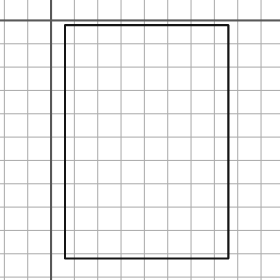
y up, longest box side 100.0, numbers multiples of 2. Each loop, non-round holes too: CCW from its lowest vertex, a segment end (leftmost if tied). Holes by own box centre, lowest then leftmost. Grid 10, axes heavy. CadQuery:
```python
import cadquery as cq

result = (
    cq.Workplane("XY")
    .moveTo(6.0, -102.0)
    .lineTo(76.0, -102.0)
    .lineTo(76.0, -2.0)
    .lineTo(6.0, -2.0)
    .close()
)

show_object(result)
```